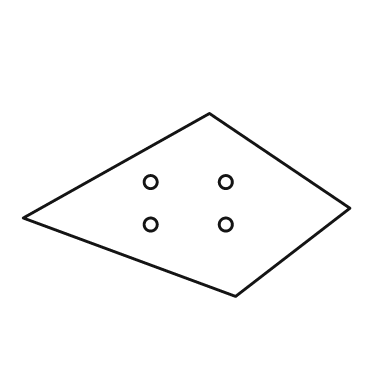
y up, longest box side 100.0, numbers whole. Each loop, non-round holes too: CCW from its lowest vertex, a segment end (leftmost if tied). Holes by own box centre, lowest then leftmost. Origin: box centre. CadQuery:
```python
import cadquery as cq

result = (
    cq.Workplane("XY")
    .moveTo(15.0, -28.0)
    .lineTo(50.0, -1.0)
    .lineTo(7.0, 28.0)
    .lineTo(-50.0, -4.0)
    .close()
    .moveTo(-11.0, -6.0)
    .circle(2.0)
    .moveTo(12.0, -6.0)
    .circle(2.0)
    .moveTo(-11.0, 7.0)
    .circle(2.0)
    .moveTo(12.0, 7.0)
    .circle(2.0)
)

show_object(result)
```